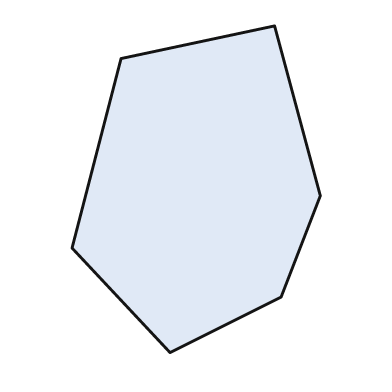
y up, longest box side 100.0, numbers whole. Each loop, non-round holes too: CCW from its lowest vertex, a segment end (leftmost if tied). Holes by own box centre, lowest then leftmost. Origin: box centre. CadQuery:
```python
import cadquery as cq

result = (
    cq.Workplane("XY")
    .moveTo(-8.0, -50.0)
    .lineTo(26.0, -33.0)
    .lineTo(38.0, -2.0)
    .lineTo(24.0, 50.0)
    .lineTo(-23.0, 40.0)
    .lineTo(-38.0, -18.0)
    .close()
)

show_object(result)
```